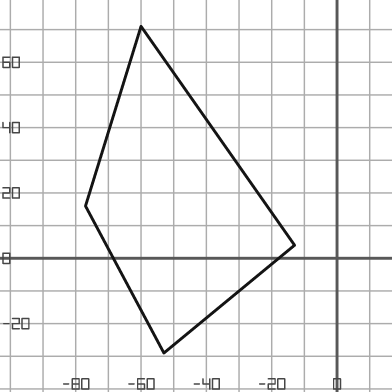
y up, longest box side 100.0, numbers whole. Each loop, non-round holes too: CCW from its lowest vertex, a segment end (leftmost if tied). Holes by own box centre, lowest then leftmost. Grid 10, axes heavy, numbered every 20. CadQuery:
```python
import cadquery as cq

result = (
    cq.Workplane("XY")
    .moveTo(-53.0, -29.0)
    .lineTo(-13.0, 4.0)
    .lineTo(-60.0, 71.0)
    .lineTo(-77.0, 16.0)
    .close()
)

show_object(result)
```